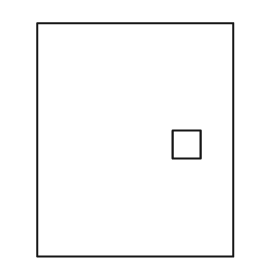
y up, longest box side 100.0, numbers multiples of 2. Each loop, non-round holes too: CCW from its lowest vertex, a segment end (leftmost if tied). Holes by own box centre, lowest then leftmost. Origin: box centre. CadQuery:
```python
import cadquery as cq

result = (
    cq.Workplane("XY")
    .moveTo(-42.0, -50.0)
    .lineTo(42.0, -50.0)
    .lineTo(42.0, 50.0)
    .lineTo(-42.0, 50.0)
    .close()
    .moveTo(16.0, -8.0)
    .lineTo(28.0, -8.0)
    .lineTo(28.0, 4.0)
    .lineTo(16.0, 4.0)
    .close()
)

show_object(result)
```